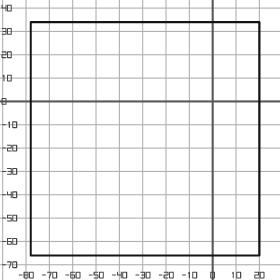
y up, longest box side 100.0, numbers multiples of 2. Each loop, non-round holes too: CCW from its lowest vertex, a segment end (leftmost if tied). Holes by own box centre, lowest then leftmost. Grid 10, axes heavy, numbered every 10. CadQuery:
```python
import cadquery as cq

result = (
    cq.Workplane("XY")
    .moveTo(-78.0, -66.0)
    .lineTo(20.0, -66.0)
    .lineTo(20.0, 34.0)
    .lineTo(-78.0, 34.0)
    .close()
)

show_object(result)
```